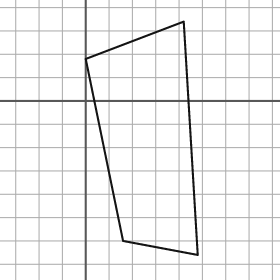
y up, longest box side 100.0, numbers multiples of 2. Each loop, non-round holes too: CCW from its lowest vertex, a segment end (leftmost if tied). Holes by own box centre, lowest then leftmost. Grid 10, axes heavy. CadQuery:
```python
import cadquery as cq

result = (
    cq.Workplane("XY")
    .moveTo(48.0, -66.0)
    .lineTo(42.0, 34.0)
    .lineTo(0.0, 18.0)
    .lineTo(16.0, -60.0)
    .close()
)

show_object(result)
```